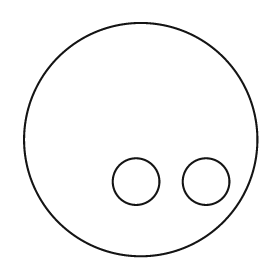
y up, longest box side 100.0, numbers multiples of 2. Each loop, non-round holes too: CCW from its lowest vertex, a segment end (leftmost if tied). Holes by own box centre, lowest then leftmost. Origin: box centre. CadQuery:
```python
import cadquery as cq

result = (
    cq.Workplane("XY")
    .moveTo(0.0, 0.0)
    .circle(50.0)
    .moveTo(-2.0, -18.0)
    .circle(10.0)
    .moveTo(28.0, -18.0)
    .circle(10.0)
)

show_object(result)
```